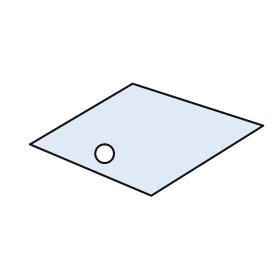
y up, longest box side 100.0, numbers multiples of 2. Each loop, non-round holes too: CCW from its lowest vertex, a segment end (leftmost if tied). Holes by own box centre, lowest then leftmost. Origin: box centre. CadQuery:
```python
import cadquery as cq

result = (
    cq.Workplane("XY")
    .moveTo(2.0, -24.0)
    .lineTo(50.0, 6.0)
    .lineTo(-6.0, 24.0)
    .lineTo(-50.0, -2.0)
    .close()
    .moveTo(-18.0, -6.0)
    .circle(4.0)
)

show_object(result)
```